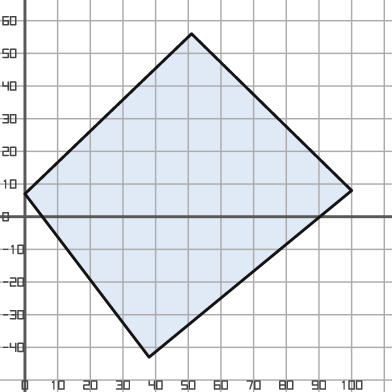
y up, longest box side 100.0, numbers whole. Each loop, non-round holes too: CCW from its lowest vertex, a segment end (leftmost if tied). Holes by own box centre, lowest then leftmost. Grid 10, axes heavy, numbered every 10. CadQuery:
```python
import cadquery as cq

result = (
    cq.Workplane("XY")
    .moveTo(38.0, -43.0)
    .lineTo(100.0, 8.0)
    .lineTo(51.0, 56.0)
    .lineTo(0.0, 7.0)
    .close()
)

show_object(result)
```